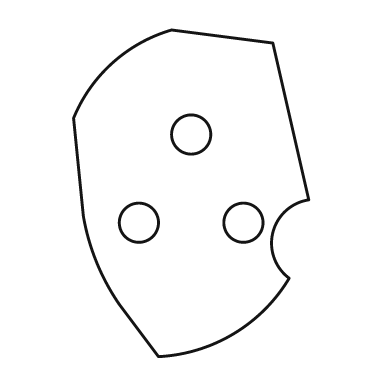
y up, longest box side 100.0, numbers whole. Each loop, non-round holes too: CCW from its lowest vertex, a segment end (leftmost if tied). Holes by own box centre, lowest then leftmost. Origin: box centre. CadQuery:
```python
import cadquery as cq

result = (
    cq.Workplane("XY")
    .moveTo(-10.0, -50.0)
    .threePointArc((13.0, -43.0), (30.0, -26.0))
    .threePointArc((25.0, -12.0), (36.0, -2.0))
    .lineTo(25.0, 46.0)
    .lineTo(-6.0, 50.0)
    .threePointArc((-24.0, 40.0), (-36.0, 23.0))
    .lineTo(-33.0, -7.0)
    .threePointArc((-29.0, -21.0), (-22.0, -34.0))
    .close()
    .moveTo(-16.0, -9.0)
    .circle(6.0)
    .moveTo(16.0, -9.0)
    .circle(6.0)
    .moveTo(0.0, 18.0)
    .circle(6.0)
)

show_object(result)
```